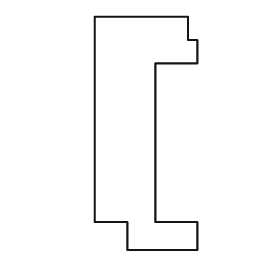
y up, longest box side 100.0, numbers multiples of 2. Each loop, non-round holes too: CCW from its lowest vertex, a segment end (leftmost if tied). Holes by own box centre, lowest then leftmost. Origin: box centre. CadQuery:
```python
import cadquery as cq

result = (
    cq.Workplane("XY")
    .moveTo(-8.0, -50.0)
    .lineTo(22.0, -50.0)
    .lineTo(22.0, -38.0)
    .lineTo(4.0, -38.0)
    .lineTo(4.0, 30.0)
    .lineTo(22.0, 30.0)
    .lineTo(22.0, 40.0)
    .lineTo(18.0, 40.0)
    .lineTo(18.0, 50.0)
    .lineTo(-22.0, 50.0)
    .lineTo(-22.0, -38.0)
    .lineTo(-8.0, -38.0)
    .close()
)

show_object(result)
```